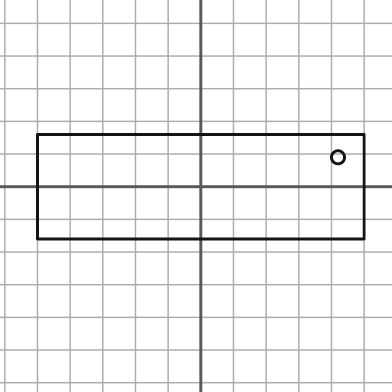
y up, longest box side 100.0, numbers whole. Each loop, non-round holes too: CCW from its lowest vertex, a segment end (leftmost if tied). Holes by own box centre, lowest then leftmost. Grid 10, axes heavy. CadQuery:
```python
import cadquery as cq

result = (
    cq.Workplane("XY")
    .moveTo(-50.0, -16.0)
    .lineTo(50.0, -16.0)
    .lineTo(50.0, 16.0)
    .lineTo(-50.0, 16.0)
    .close()
    .moveTo(42.0, 9.0)
    .circle(2.0)
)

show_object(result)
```